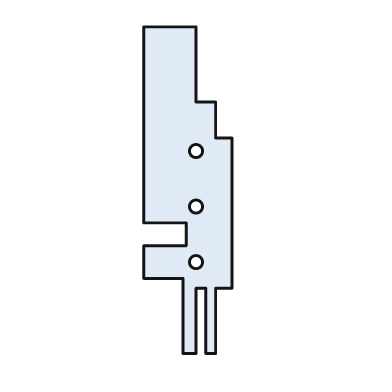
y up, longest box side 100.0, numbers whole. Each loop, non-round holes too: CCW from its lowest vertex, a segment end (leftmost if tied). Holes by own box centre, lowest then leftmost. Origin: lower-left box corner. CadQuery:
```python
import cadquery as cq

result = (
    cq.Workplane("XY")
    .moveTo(12.0, 0.0)
    .lineTo(16.0, 0.0)
    .lineTo(16.0, 20.0)
    .lineTo(19.0, 20.0)
    .lineTo(19.0, 0.0)
    .lineTo(22.0, 0.0)
    .lineTo(22.0, 20.0)
    .lineTo(27.0, 20.0)
    .lineTo(27.0, 66.0)
    .lineTo(22.0, 66.0)
    .lineTo(22.0, 77.0)
    .lineTo(16.0, 77.0)
    .lineTo(16.0, 100.0)
    .lineTo(0.0, 100.0)
    .lineTo(0.0, 40.0)
    .lineTo(13.0, 40.0)
    .lineTo(13.0, 33.0)
    .lineTo(0.0, 33.0)
    .lineTo(0.0, 23.0)
    .lineTo(12.0, 23.0)
    .close()
    .moveTo(16.0, 28.0)
    .circle(2.0)
    .moveTo(16.0, 45.0)
    .circle(2.0)
    .moveTo(16.0, 62.0)
    .circle(2.0)
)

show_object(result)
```